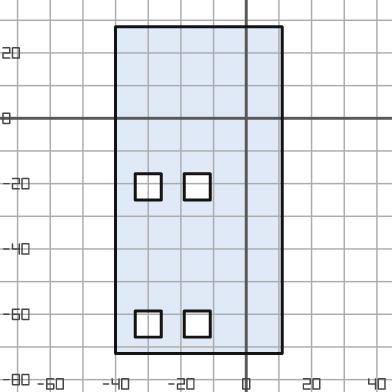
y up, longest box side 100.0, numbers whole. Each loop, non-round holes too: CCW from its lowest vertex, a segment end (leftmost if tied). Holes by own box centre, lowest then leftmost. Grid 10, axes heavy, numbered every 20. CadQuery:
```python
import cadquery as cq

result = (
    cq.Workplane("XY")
    .moveTo(-40.0, -72.0)
    .lineTo(11.0, -72.0)
    .lineTo(11.0, 28.0)
    .lineTo(-40.0, 28.0)
    .close()
    .moveTo(-34.0, -67.0)
    .lineTo(-26.0, -67.0)
    .lineTo(-26.0, -59.0)
    .lineTo(-34.0, -59.0)
    .close()
    .moveTo(-19.0, -67.0)
    .lineTo(-11.0, -67.0)
    .lineTo(-11.0, -59.0)
    .lineTo(-19.0, -59.0)
    .close()
    .moveTo(-34.0, -25.0)
    .lineTo(-26.0, -25.0)
    .lineTo(-26.0, -17.0)
    .lineTo(-34.0, -17.0)
    .close()
    .moveTo(-19.0, -25.0)
    .lineTo(-11.0, -25.0)
    .lineTo(-11.0, -17.0)
    .lineTo(-19.0, -17.0)
    .close()
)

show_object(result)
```